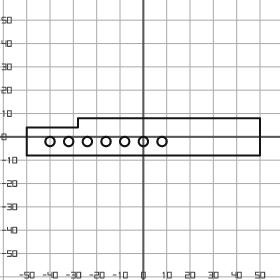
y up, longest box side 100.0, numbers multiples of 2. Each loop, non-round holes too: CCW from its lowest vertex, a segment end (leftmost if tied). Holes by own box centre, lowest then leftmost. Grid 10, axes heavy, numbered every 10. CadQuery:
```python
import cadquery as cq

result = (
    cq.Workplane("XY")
    .moveTo(-50.0, -8.0)
    .lineTo(50.0, -8.0)
    .lineTo(50.0, 8.0)
    .lineTo(-28.0, 8.0)
    .lineTo(-28.0, 4.0)
    .lineTo(-50.0, 4.0)
    .close()
    .moveTo(-40.0, -2.0)
    .circle(2.0)
    .moveTo(-32.0, -2.0)
    .circle(2.0)
    .moveTo(-24.0, -2.0)
    .circle(2.0)
    .moveTo(-16.0, -2.0)
    .circle(2.0)
    .moveTo(-8.0, -2.0)
    .circle(2.0)
    .moveTo(0.0, -2.0)
    .circle(2.0)
    .moveTo(8.0, -2.0)
    .circle(2.0)
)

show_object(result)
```